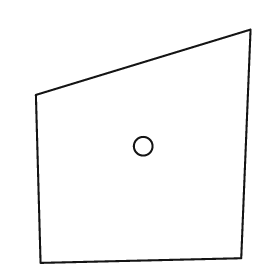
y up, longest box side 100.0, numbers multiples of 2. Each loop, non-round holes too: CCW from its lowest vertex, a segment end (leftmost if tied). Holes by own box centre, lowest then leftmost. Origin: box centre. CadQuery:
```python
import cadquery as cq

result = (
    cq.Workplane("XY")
    .moveTo(-44.0, -50.0)
    .lineTo(42.0, -48.0)
    .lineTo(46.0, 50.0)
    .lineTo(-46.0, 22.0)
    .close()
    .moveTo(0.0, 0.0)
    .circle(4.0)
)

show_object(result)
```